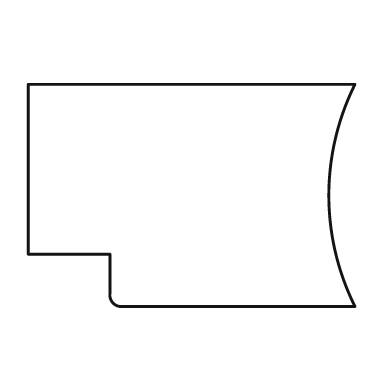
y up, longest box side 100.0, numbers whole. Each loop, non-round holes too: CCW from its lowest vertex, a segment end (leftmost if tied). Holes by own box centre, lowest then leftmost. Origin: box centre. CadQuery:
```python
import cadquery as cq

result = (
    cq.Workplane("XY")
    .moveTo(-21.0, -34.0)
    .lineTo(50.0, -34.0)
    .threePointArc((42.0, 0.0), (50.0, 34.0))
    .lineTo(-50.0, 34.0)
    .lineTo(-50.0, -18.0)
    .lineTo(-25.0, -18.0)
    .lineTo(-25.0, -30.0)
    .threePointArc((-24.0, -33.0), (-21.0, -34.0))
    .close()
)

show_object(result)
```